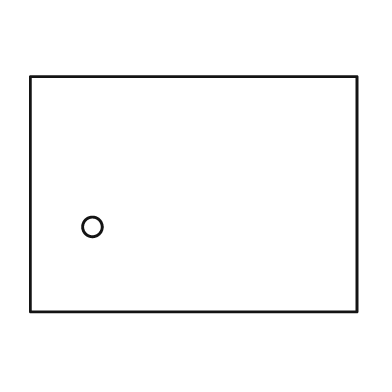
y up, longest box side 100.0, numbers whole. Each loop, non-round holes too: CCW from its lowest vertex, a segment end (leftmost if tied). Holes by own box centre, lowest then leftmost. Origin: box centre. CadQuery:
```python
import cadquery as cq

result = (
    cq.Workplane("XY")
    .moveTo(-50.0, -36.0)
    .lineTo(50.0, -36.0)
    .lineTo(50.0, 36.0)
    .lineTo(-50.0, 36.0)
    .close()
    .moveTo(-31.0, -10.0)
    .circle(3.0)
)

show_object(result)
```